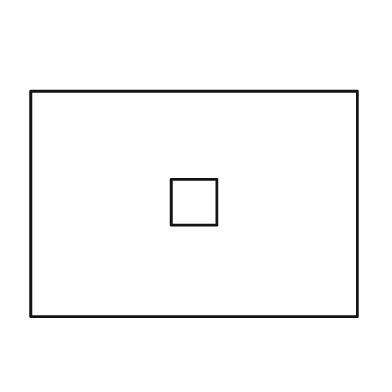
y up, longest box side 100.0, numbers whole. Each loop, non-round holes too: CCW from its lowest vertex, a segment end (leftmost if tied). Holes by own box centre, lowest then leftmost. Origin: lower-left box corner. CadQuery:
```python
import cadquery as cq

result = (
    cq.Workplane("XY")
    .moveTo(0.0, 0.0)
    .lineTo(100.0, 0.0)
    .lineTo(100.0, 69.0)
    .lineTo(0.0, 69.0)
    .close()
    .moveTo(43.0, 28.0)
    .lineTo(57.0, 28.0)
    .lineTo(57.0, 42.0)
    .lineTo(43.0, 42.0)
    .close()
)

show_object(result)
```